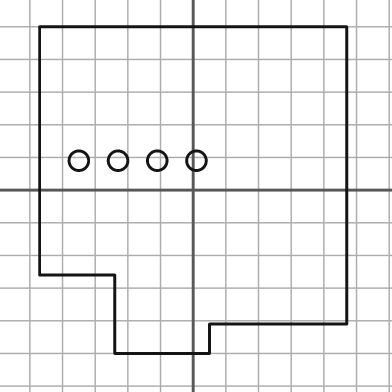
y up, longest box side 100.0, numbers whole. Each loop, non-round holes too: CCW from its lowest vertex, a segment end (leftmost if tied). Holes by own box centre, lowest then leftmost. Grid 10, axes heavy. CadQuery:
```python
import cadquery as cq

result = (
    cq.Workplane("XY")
    .moveTo(-24.0, -50.0)
    .lineTo(5.0, -50.0)
    .lineTo(5.0, -41.0)
    .lineTo(47.0, -41.0)
    .lineTo(47.0, 50.0)
    .lineTo(-47.0, 50.0)
    .lineTo(-47.0, -26.0)
    .lineTo(-24.0, -26.0)
    .close()
    .moveTo(-35.0, 9.0)
    .circle(3.0)
    .moveTo(-23.0, 9.0)
    .circle(3.0)
    .moveTo(-11.0, 9.0)
    .circle(3.0)
    .moveTo(1.0, 9.0)
    .circle(3.0)
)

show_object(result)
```